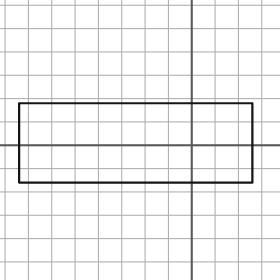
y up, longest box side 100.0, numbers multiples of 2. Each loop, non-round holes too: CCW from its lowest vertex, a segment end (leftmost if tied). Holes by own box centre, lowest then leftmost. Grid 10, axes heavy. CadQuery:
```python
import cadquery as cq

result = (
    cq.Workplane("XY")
    .moveTo(-74.0, -16.0)
    .lineTo(26.0, -16.0)
    .lineTo(26.0, 18.0)
    .lineTo(-74.0, 18.0)
    .close()
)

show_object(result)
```